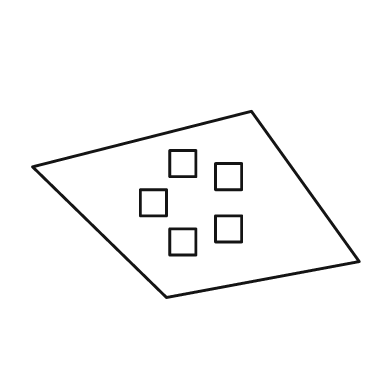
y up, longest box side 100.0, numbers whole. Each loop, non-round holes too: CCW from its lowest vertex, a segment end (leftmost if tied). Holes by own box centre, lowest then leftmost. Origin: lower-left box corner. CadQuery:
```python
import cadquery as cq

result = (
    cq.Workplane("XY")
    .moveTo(41.0, 0.0)
    .lineTo(100.0, 11.0)
    .lineTo(67.0, 57.0)
    .lineTo(0.0, 40.0)
    .close()
    .moveTo(42.0, 13.0)
    .lineTo(50.0, 13.0)
    .lineTo(50.0, 21.0)
    .lineTo(42.0, 21.0)
    .close()
    .moveTo(56.0, 17.0)
    .lineTo(64.0, 17.0)
    .lineTo(64.0, 25.0)
    .lineTo(56.0, 25.0)
    .close()
    .moveTo(33.0, 25.0)
    .lineTo(41.0, 25.0)
    .lineTo(41.0, 33.0)
    .lineTo(33.0, 33.0)
    .close()
    .moveTo(56.0, 33.0)
    .lineTo(64.0, 33.0)
    .lineTo(64.0, 41.0)
    .lineTo(56.0, 41.0)
    .close()
    .moveTo(42.0, 37.0)
    .lineTo(50.0, 37.0)
    .lineTo(50.0, 45.0)
    .lineTo(42.0, 45.0)
    .close()
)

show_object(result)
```